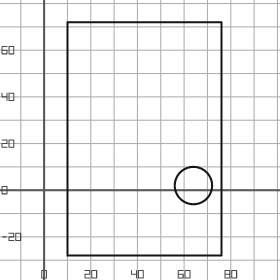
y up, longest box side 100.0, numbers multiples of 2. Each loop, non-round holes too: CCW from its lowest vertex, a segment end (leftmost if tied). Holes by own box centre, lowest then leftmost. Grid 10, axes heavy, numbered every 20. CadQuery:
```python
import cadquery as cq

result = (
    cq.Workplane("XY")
    .moveTo(10.0, -28.0)
    .lineTo(76.0, -28.0)
    .lineTo(76.0, 72.0)
    .lineTo(10.0, 72.0)
    .close()
    .moveTo(64.0, 2.0)
    .circle(8.0)
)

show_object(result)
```